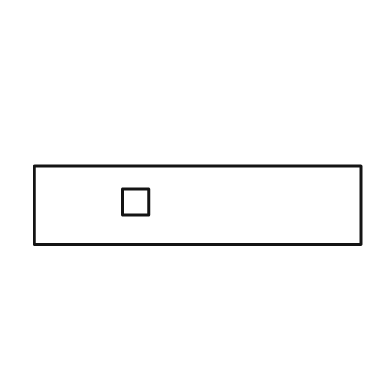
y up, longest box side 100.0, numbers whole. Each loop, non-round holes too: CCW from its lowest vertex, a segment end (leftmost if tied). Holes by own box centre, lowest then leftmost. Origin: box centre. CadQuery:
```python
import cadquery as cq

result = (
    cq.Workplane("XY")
    .moveTo(-50.0, -12.0)
    .lineTo(50.0, -12.0)
    .lineTo(50.0, 12.0)
    .lineTo(-50.0, 12.0)
    .close()
    .moveTo(-23.0, -3.0)
    .lineTo(-15.0, -3.0)
    .lineTo(-15.0, 5.0)
    .lineTo(-23.0, 5.0)
    .close()
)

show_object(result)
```